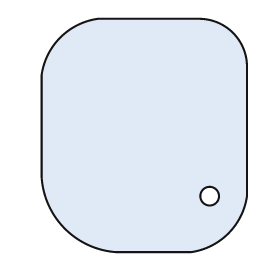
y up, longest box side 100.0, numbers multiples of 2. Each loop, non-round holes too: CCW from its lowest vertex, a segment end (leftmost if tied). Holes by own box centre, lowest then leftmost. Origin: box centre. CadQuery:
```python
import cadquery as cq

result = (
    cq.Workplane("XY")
    .moveTo(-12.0, -50.0)
    .lineTo(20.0, -50.0)
    .threePointArc((36.0, -42.0), (44.0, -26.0))
    .lineTo(44.0, 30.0)
    .threePointArc((38.0, 44.0), (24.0, 50.0))
    .lineTo(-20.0, 50.0)
    .threePointArc((-36.0, 42.0), (-44.0, 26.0))
    .lineTo(-44.0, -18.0)
    .threePointArc((-34.0, -40.0), (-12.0, -50.0))
    .close()
    .moveTo(28.0, -26.0)
    .circle(4.0)
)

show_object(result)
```